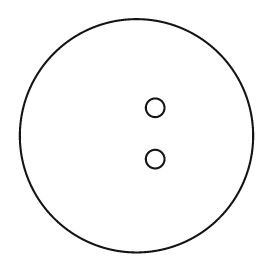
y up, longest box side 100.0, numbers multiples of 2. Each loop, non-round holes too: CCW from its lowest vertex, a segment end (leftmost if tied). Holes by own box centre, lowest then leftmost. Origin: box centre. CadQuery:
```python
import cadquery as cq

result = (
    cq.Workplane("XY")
    .moveTo(0.0, 0.0)
    .circle(50.0)
    .moveTo(8.0, -10.0)
    .circle(4.0)
    .moveTo(8.0, 12.0)
    .circle(4.0)
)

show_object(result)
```